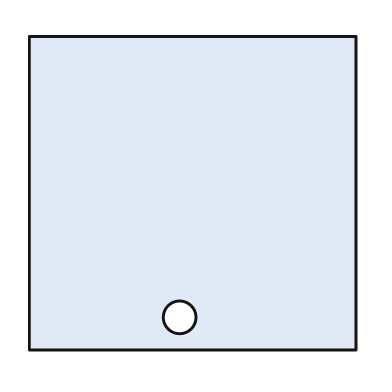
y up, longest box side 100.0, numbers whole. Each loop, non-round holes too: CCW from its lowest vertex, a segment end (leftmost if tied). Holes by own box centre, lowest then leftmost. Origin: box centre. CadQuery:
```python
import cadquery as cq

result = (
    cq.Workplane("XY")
    .moveTo(-50.0, -48.0)
    .lineTo(50.0, -48.0)
    .lineTo(50.0, 48.0)
    .lineTo(-50.0, 48.0)
    .close()
    .moveTo(-4.0, -38.0)
    .circle(5.0)
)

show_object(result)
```